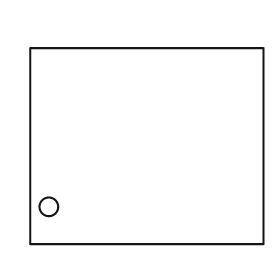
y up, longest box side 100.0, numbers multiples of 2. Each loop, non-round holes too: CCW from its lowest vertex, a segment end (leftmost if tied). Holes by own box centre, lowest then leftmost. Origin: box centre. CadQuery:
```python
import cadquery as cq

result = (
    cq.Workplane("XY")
    .moveTo(-50.0, -42.0)
    .lineTo(50.0, -42.0)
    .lineTo(50.0, 42.0)
    .lineTo(-50.0, 42.0)
    .close()
    .moveTo(-42.0, -26.0)
    .circle(4.0)
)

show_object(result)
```